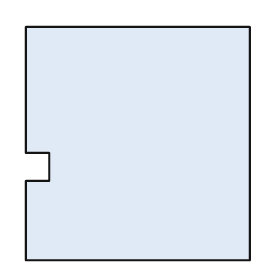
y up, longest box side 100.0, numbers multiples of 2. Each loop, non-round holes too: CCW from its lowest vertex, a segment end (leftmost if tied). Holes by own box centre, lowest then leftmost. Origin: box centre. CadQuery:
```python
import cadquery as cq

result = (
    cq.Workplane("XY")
    .moveTo(-48.0, -50.0)
    .lineTo(48.0, -50.0)
    .lineTo(48.0, 50.0)
    .lineTo(-48.0, 50.0)
    .lineTo(-48.0, -4.0)
    .lineTo(-38.0, -4.0)
    .lineTo(-38.0, -16.0)
    .lineTo(-48.0, -16.0)
    .close()
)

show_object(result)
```